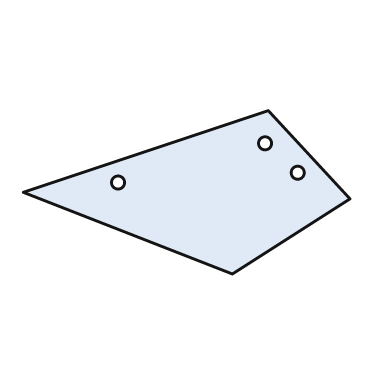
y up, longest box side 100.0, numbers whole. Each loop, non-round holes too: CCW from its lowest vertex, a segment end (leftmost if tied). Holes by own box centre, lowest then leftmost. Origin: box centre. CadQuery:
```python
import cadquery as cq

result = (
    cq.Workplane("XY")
    .moveTo(14.0, -25.0)
    .lineTo(50.0, -2.0)
    .lineTo(25.0, 25.0)
    .lineTo(-50.0, 0.0)
    .close()
    .moveTo(-21.0, 3.0)
    .circle(2.0)
    .moveTo(34.0, 6.0)
    .circle(2.0)
    .moveTo(24.0, 15.0)
    .circle(2.0)
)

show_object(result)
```